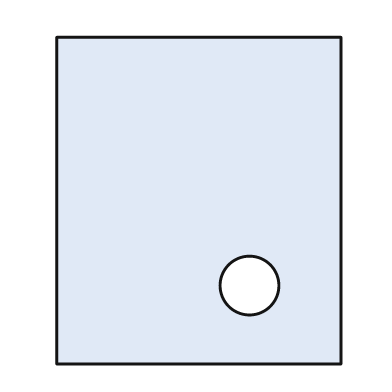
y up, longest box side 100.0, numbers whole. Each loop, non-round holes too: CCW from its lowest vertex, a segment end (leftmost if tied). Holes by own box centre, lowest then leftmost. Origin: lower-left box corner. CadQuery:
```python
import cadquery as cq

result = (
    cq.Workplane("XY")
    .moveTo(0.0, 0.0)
    .lineTo(87.0, 0.0)
    .lineTo(87.0, 100.0)
    .lineTo(0.0, 100.0)
    .close()
    .moveTo(59.0, 24.0)
    .circle(9.0)
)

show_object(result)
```